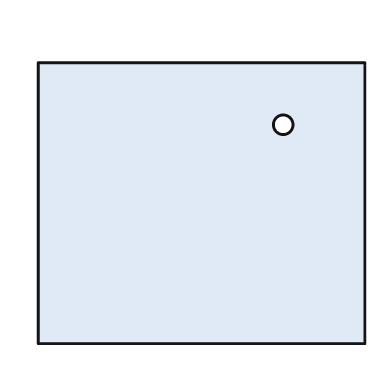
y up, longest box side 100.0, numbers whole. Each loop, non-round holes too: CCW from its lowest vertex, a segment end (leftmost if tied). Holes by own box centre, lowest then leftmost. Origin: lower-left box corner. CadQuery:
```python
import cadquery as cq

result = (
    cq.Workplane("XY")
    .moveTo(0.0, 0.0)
    .lineTo(100.0, 0.0)
    .lineTo(100.0, 86.0)
    .lineTo(0.0, 86.0)
    .close()
    .moveTo(75.0, 67.0)
    .circle(3.0)
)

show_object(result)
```